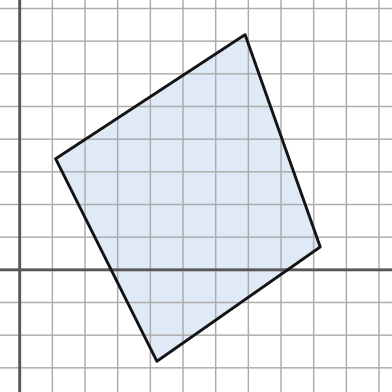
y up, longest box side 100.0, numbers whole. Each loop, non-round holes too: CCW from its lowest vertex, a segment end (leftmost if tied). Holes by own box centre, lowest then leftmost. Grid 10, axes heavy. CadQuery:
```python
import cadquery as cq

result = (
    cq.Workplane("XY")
    .moveTo(42.0, -28.0)
    .lineTo(92.0, 7.0)
    .lineTo(69.0, 72.0)
    .lineTo(11.0, 34.0)
    .close()
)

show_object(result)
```